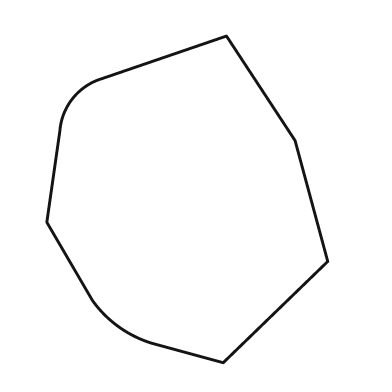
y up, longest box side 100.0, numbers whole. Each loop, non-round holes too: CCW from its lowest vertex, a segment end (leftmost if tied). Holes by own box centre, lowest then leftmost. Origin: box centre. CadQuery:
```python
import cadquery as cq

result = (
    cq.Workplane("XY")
    .moveTo(11.0, -50.0)
    .lineTo(43.0, -19.0)
    .lineTo(33.0, 18.0)
    .lineTo(12.0, 50.0)
    .lineTo(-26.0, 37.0)
    .threePointArc((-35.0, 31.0), (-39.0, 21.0))
    .lineTo(-43.0, -7.0)
    .lineTo(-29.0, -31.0)
    .threePointArc((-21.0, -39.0), (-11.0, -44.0))
    .close()
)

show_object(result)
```